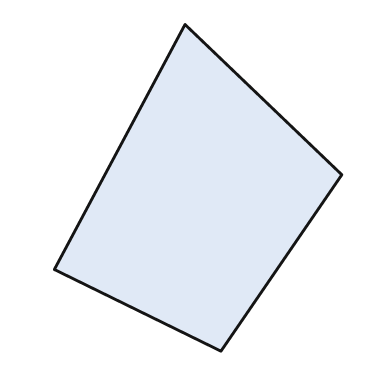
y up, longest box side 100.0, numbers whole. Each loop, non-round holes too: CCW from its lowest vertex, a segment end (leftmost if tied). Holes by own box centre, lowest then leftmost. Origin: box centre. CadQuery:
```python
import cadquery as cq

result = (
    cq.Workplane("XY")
    .moveTo(7.0, -50.0)
    .lineTo(44.0, 4.0)
    .lineTo(-4.0, 50.0)
    .lineTo(-44.0, -25.0)
    .close()
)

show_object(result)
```